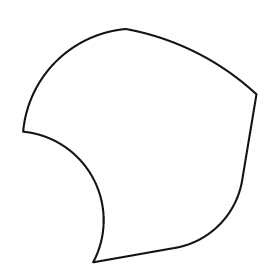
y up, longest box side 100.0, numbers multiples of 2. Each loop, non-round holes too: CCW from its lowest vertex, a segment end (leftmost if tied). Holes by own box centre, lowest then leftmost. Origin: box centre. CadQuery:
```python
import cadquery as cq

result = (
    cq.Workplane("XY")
    .moveTo(-20.0, -50.0)
    .lineTo(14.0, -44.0)
    .threePointArc((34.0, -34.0), (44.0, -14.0))
    .lineTo(50.0, 22.0)
    .threePointArc((24.0, 40.0), (-6.0, 50.0))
    .threePointArc((-36.0, 36.0), (-50.0, 6.0))
    .threePointArc((-20.0, -14.0), (-20.0, -50.0))
    .close()
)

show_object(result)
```